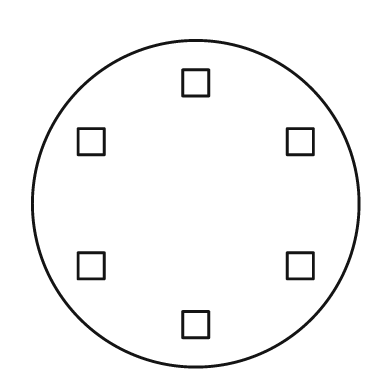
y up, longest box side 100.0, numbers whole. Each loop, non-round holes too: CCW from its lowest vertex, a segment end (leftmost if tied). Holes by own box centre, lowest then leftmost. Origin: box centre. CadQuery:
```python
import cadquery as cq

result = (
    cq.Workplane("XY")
    .moveTo(0.0, 0.0)
    .circle(50.0)
    .moveTo(-4.0, -41.0)
    .lineTo(4.0, -41.0)
    .lineTo(4.0, -33.0)
    .lineTo(-4.0, -33.0)
    .close()
    .moveTo(-36.0, -23.0)
    .lineTo(-28.0, -23.0)
    .lineTo(-28.0, -15.0)
    .lineTo(-36.0, -15.0)
    .close()
    .moveTo(28.0, -23.0)
    .lineTo(36.0, -23.0)
    .lineTo(36.0, -15.0)
    .lineTo(28.0, -15.0)
    .close()
    .moveTo(-36.0, 15.0)
    .lineTo(-28.0, 15.0)
    .lineTo(-28.0, 23.0)
    .lineTo(-36.0, 23.0)
    .close()
    .moveTo(28.0, 15.0)
    .lineTo(36.0, 15.0)
    .lineTo(36.0, 23.0)
    .lineTo(28.0, 23.0)
    .close()
    .moveTo(-4.0, 33.0)
    .lineTo(4.0, 33.0)
    .lineTo(4.0, 41.0)
    .lineTo(-4.0, 41.0)
    .close()
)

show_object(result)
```